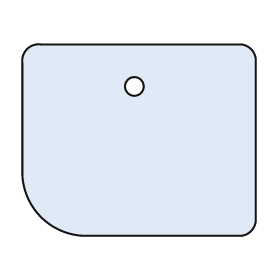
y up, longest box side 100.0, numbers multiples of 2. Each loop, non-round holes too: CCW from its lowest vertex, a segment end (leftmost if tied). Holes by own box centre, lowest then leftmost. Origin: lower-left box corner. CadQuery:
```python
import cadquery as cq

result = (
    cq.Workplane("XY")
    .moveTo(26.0, 0.0)
    .lineTo(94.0, 0.0)
    .threePointArc((98.0, 2.0), (100.0, 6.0))
    .lineTo(100.0, 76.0)
    .threePointArc((98.0, 80.0), (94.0, 82.0))
    .lineTo(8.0, 82.0)
    .threePointArc((2.0, 80.0), (0.0, 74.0))
    .lineTo(0.0, 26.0)
    .threePointArc((8.0, 8.0), (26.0, 0.0))
    .close()
    .moveTo(48.0, 64.0)
    .circle(4.0)
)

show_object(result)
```